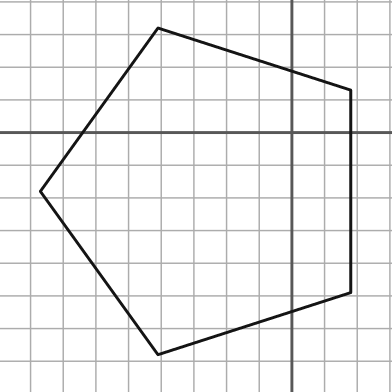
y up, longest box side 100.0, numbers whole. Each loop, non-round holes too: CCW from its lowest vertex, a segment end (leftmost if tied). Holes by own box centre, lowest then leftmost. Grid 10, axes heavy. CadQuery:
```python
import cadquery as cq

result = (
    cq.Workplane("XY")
    .moveTo(-41.0, -68.0)
    .lineTo(18.0, -49.0)
    .lineTo(18.0, 13.0)
    .lineTo(-41.0, 32.0)
    .lineTo(-77.0, -18.0)
    .close()
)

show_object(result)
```